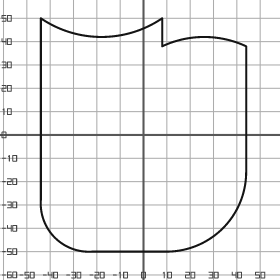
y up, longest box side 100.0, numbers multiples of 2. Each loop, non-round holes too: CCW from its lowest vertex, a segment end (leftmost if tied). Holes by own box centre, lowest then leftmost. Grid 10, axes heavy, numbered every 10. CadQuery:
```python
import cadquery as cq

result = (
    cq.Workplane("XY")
    .moveTo(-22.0, -50.0)
    .lineTo(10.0, -50.0)
    .threePointArc((34.0, -40.0), (44.0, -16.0))
    .lineTo(44.0, 38.0)
    .threePointArc((26.0, 42.0), (8.0, 38.0))
    .lineTo(8.0, 50.0)
    .threePointArc((-18.0, 42.0), (-44.0, 50.0))
    .lineTo(-44.0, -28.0)
    .threePointArc((-38.0, -44.0), (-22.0, -50.0))
    .close()
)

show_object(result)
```